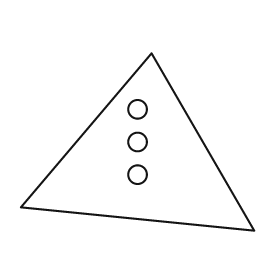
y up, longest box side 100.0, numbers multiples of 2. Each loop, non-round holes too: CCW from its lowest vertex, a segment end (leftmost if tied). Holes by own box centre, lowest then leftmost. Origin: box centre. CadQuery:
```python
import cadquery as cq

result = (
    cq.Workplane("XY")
    .moveTo(50.0, -38.0)
    .lineTo(6.0, 38.0)
    .lineTo(-50.0, -28.0)
    .close()
    .moveTo(0.0, -14.0)
    .circle(4.0)
    .moveTo(0.0, 0.0)
    .circle(4.0)
    .moveTo(0.0, 14.0)
    .circle(4.0)
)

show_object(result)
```